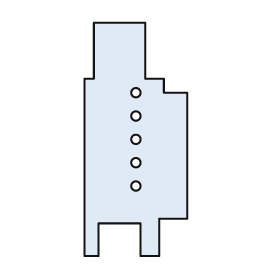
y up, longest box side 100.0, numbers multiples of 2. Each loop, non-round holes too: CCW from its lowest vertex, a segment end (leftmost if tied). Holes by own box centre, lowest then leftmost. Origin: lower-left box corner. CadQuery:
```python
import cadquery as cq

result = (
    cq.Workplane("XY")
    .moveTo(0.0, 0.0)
    .lineTo(6.0, 0.0)
    .lineTo(6.0, 14.0)
    .lineTo(24.0, 14.0)
    .lineTo(24.0, 0.0)
    .lineTo(32.0, 0.0)
    .lineTo(32.0, 16.0)
    .lineTo(44.0, 16.0)
    .lineTo(44.0, 70.0)
    .lineTo(34.0, 70.0)
    .lineTo(34.0, 76.0)
    .lineTo(26.0, 76.0)
    .lineTo(26.0, 100.0)
    .lineTo(4.0, 100.0)
    .lineTo(4.0, 76.0)
    .lineTo(0.0, 76.0)
    .close()
    .moveTo(22.0, 30.0)
    .circle(2.0)
    .moveTo(22.0, 40.0)
    .circle(2.0)
    .moveTo(22.0, 50.0)
    .circle(2.0)
    .moveTo(22.0, 60.0)
    .circle(2.0)
    .moveTo(22.0, 70.0)
    .circle(2.0)
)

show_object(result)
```